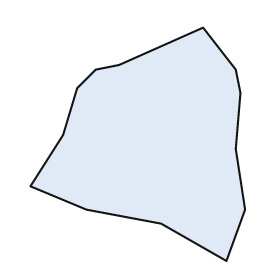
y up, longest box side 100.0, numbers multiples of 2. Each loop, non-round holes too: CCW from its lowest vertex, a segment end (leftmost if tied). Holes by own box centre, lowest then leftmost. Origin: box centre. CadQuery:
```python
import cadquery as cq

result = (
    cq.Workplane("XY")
    .moveTo(38.0, -50.0)
    .lineTo(46.0, -28.0)
    .lineTo(42.0, -2.0)
    .lineTo(44.0, 22.0)
    .lineTo(42.0, 32.0)
    .lineTo(28.0, 50.0)
    .lineTo(-8.0, 34.0)
    .lineTo(-18.0, 32.0)
    .lineTo(-26.0, 24.0)
    .lineTo(-32.0, 4.0)
    .lineTo(-46.0, -18.0)
    .lineTo(-22.0, -28.0)
    .lineTo(10.0, -34.0)
    .close()
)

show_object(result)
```